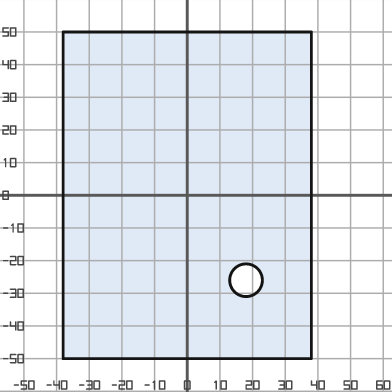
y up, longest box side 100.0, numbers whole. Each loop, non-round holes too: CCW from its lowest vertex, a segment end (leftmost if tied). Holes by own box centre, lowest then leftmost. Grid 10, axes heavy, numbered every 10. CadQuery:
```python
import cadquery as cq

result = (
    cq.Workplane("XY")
    .moveTo(-38.0, -50.0)
    .lineTo(38.0, -50.0)
    .lineTo(38.0, 50.0)
    .lineTo(-38.0, 50.0)
    .close()
    .moveTo(18.0, -26.0)
    .circle(5.0)
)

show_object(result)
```